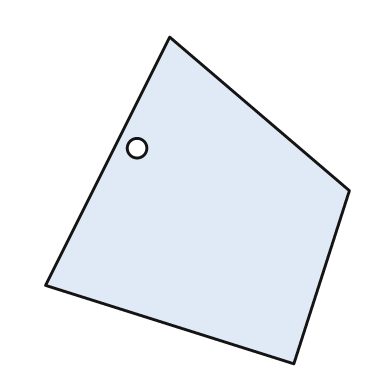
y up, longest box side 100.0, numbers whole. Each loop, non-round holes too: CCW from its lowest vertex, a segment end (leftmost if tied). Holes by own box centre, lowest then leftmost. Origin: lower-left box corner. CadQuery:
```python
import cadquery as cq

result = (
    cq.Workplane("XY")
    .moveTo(76.0, 0.0)
    .lineTo(93.0, 53.0)
    .lineTo(38.0, 100.0)
    .lineTo(0.0, 24.0)
    .close()
    .moveTo(28.0, 66.0)
    .circle(3.0)
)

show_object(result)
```